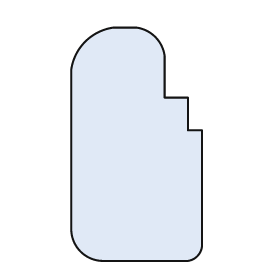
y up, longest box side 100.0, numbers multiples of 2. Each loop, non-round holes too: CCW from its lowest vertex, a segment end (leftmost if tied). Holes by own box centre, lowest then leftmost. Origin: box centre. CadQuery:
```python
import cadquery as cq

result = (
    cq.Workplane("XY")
    .moveTo(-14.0, -50.0)
    .lineTo(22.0, -50.0)
    .threePointArc((26.0, -48.0), (28.0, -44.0))
    .lineTo(28.0, 6.0)
    .lineTo(22.0, 6.0)
    .lineTo(22.0, 20.0)
    .lineTo(12.0, 20.0)
    .lineTo(12.0, 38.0)
    .threePointArc((8.0, 46.0), (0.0, 50.0))
    .lineTo(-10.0, 50.0)
    .threePointArc((-22.0, 44.0), (-28.0, 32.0))
    .lineTo(-28.0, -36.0)
    .threePointArc((-24.0, -46.0), (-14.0, -50.0))
    .close()
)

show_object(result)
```